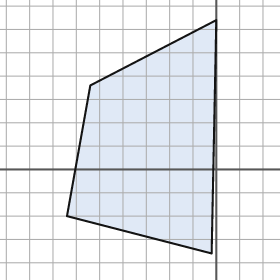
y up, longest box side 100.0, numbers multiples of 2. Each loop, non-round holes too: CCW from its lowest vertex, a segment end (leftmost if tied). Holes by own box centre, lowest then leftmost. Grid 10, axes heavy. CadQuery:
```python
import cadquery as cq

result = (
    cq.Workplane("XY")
    .moveTo(-2.0, -36.0)
    .lineTo(0.0, 64.0)
    .lineTo(-54.0, 36.0)
    .lineTo(-64.0, -20.0)
    .close()
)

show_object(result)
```